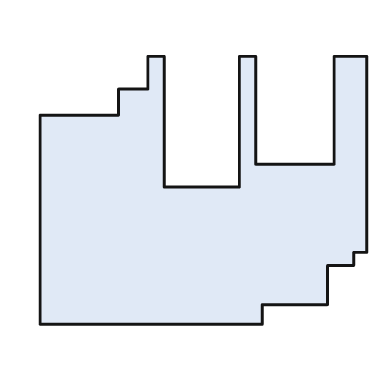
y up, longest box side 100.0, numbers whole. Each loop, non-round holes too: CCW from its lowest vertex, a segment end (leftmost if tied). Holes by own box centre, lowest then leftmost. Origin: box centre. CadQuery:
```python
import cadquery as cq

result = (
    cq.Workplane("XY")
    .moveTo(-50.0, -41.0)
    .lineTo(18.0, -41.0)
    .lineTo(18.0, -35.0)
    .lineTo(38.0, -35.0)
    .lineTo(38.0, -23.0)
    .lineTo(46.0, -23.0)
    .lineTo(46.0, -19.0)
    .lineTo(50.0, -19.0)
    .lineTo(50.0, 41.0)
    .lineTo(40.0, 41.0)
    .lineTo(40.0, 8.0)
    .lineTo(16.0, 8.0)
    .lineTo(16.0, 41.0)
    .lineTo(11.0, 41.0)
    .lineTo(11.0, 1.0)
    .lineTo(-12.0, 1.0)
    .lineTo(-12.0, 41.0)
    .lineTo(-17.0, 41.0)
    .lineTo(-17.0, 31.0)
    .lineTo(-26.0, 31.0)
    .lineTo(-26.0, 23.0)
    .lineTo(-50.0, 23.0)
    .close()
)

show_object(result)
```